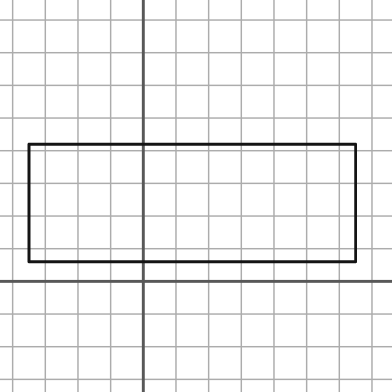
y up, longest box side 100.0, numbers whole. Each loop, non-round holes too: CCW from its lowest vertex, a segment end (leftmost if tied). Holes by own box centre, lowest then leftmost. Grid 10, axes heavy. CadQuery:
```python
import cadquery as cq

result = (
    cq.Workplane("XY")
    .moveTo(-35.0, 6.0)
    .lineTo(65.0, 6.0)
    .lineTo(65.0, 42.0)
    .lineTo(-35.0, 42.0)
    .close()
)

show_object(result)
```